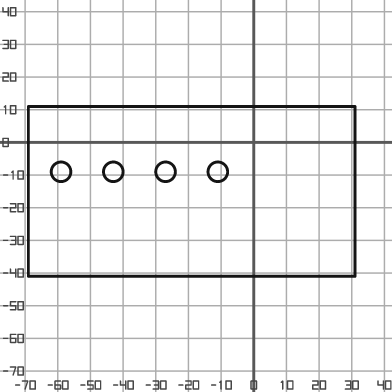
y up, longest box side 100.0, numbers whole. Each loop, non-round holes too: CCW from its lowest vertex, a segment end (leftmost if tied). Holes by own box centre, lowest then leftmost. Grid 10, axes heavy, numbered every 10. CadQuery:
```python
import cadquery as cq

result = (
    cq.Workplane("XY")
    .moveTo(-69.0, -41.0)
    .lineTo(31.0, -41.0)
    .lineTo(31.0, 11.0)
    .lineTo(-69.0, 11.0)
    .close()
    .moveTo(-59.0, -9.0)
    .circle(3.0)
    .moveTo(-43.0, -9.0)
    .circle(3.0)
    .moveTo(-27.0, -9.0)
    .circle(3.0)
    .moveTo(-11.0, -9.0)
    .circle(3.0)
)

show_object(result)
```